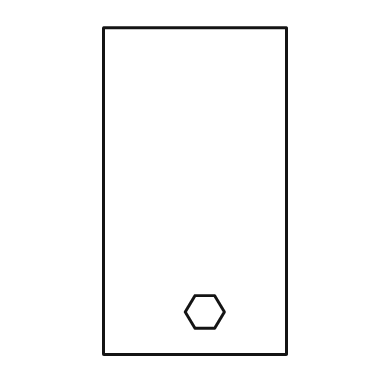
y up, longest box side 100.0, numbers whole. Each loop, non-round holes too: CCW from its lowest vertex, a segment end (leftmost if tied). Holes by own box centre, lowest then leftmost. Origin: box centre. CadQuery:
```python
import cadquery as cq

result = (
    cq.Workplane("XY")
    .moveTo(-28.0, -50.0)
    .lineTo(28.0, -50.0)
    .lineTo(28.0, 50.0)
    .lineTo(-28.0, 50.0)
    .close()
    .moveTo(0.0, -42.0)
    .lineTo(6.0, -42.0)
    .lineTo(9.0, -37.0)
    .lineTo(6.0, -32.0)
    .lineTo(0.0, -32.0)
    .lineTo(-3.0, -37.0)
    .close()
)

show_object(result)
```